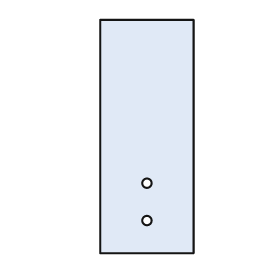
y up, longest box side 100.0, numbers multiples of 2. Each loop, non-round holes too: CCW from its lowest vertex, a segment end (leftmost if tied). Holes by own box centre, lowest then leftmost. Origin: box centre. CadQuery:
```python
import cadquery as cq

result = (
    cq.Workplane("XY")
    .moveTo(-20.0, -50.0)
    .lineTo(20.0, -50.0)
    .lineTo(20.0, 50.0)
    .lineTo(-20.0, 50.0)
    .close()
    .moveTo(0.0, -36.0)
    .circle(2.0)
    .moveTo(0.0, -20.0)
    .circle(2.0)
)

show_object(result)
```